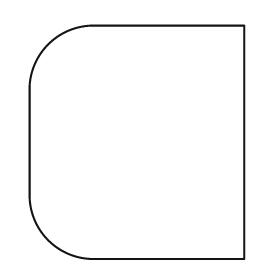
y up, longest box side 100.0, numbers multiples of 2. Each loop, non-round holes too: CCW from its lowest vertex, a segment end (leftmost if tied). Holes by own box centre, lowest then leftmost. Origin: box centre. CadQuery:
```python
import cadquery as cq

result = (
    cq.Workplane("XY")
    .moveTo(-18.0, -50.0)
    .lineTo(46.0, -50.0)
    .lineTo(46.0, 50.0)
    .lineTo(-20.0, 50.0)
    .threePointArc((-38.0, 42.0), (-46.0, 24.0))
    .lineTo(-46.0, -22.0)
    .threePointArc((-38.0, -42.0), (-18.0, -50.0))
    .close()
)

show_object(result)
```